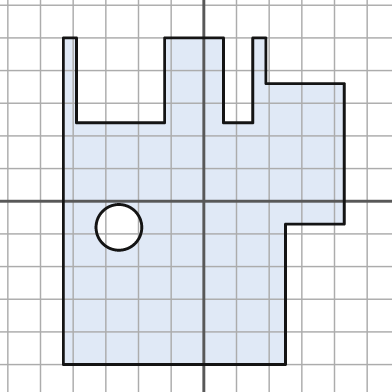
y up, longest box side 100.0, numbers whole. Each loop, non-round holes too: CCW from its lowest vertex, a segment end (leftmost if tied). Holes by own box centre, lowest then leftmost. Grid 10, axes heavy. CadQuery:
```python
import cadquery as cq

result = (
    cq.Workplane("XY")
    .moveTo(-43.0, -50.0)
    .lineTo(25.0, -50.0)
    .lineTo(25.0, -7.0)
    .lineTo(43.0, -7.0)
    .lineTo(43.0, 36.0)
    .lineTo(19.0, 36.0)
    .lineTo(19.0, 50.0)
    .lineTo(15.0, 50.0)
    .lineTo(15.0, 24.0)
    .lineTo(6.0, 24.0)
    .lineTo(6.0, 50.0)
    .lineTo(-12.0, 50.0)
    .lineTo(-12.0, 24.0)
    .lineTo(-39.0, 24.0)
    .lineTo(-39.0, 50.0)
    .lineTo(-43.0, 50.0)
    .close()
    .moveTo(-26.0, -8.0)
    .circle(7.0)
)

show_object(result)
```